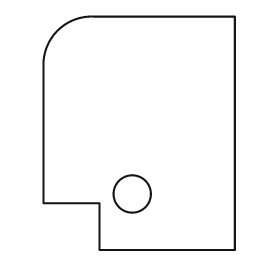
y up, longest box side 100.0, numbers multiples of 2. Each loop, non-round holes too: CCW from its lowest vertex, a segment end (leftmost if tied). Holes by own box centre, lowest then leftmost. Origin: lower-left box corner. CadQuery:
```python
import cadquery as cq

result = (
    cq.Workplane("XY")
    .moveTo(24.0, 0.0)
    .lineTo(82.0, 0.0)
    .lineTo(82.0, 100.0)
    .lineTo(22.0, 100.0)
    .threePointArc((6.0, 94.0), (0.0, 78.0))
    .lineTo(0.0, 20.0)
    .lineTo(24.0, 20.0)
    .close()
    .moveTo(38.0, 24.0)
    .circle(8.0)
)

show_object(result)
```